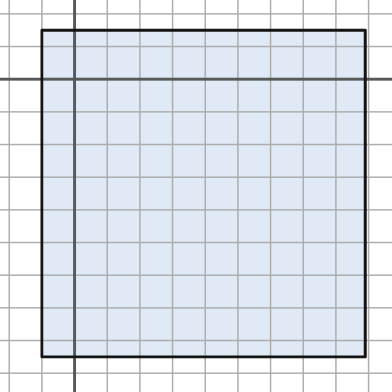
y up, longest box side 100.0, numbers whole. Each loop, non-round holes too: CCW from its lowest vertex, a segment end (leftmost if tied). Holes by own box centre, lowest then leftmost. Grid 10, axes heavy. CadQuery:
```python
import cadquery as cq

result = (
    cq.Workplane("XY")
    .moveTo(-10.0, -85.0)
    .lineTo(89.0, -85.0)
    .lineTo(89.0, 15.0)
    .lineTo(-10.0, 15.0)
    .close()
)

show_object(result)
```